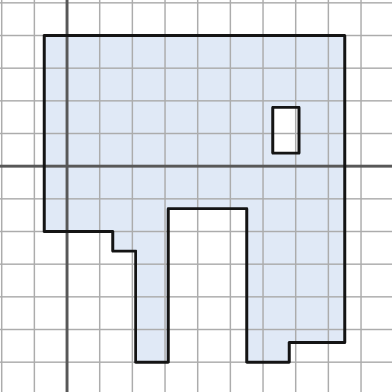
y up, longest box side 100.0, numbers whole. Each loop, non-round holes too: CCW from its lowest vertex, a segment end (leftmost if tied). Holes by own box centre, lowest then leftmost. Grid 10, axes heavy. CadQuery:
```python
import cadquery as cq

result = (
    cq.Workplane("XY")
    .moveTo(21.0, -60.0)
    .lineTo(31.0, -60.0)
    .lineTo(31.0, -13.0)
    .lineTo(55.0, -13.0)
    .lineTo(55.0, -60.0)
    .lineTo(68.0, -60.0)
    .lineTo(68.0, -54.0)
    .lineTo(85.0, -54.0)
    .lineTo(85.0, 40.0)
    .lineTo(-7.0, 40.0)
    .lineTo(-7.0, -20.0)
    .lineTo(14.0, -20.0)
    .lineTo(14.0, -26.0)
    .lineTo(21.0, -26.0)
    .close()
    .moveTo(63.0, 4.0)
    .lineTo(71.0, 4.0)
    .lineTo(71.0, 18.0)
    .lineTo(63.0, 18.0)
    .close()
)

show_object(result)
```